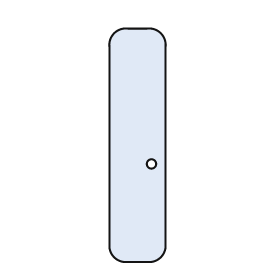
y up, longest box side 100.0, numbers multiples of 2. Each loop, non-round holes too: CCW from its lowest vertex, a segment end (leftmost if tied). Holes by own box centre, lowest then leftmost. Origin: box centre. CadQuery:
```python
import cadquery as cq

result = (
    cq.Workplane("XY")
    .moveTo(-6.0, -50.0)
    .lineTo(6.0, -50.0)
    .threePointArc((10.0, -48.0), (12.0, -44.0))
    .lineTo(12.0, 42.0)
    .threePointArc((10.0, 48.0), (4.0, 50.0))
    .lineTo(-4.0, 50.0)
    .threePointArc((-10.0, 48.0), (-12.0, 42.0))
    .lineTo(-12.0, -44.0)
    .threePointArc((-10.0, -48.0), (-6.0, -50.0))
    .close()
    .moveTo(6.0, -8.0)
    .circle(2.0)
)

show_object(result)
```